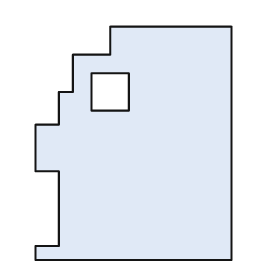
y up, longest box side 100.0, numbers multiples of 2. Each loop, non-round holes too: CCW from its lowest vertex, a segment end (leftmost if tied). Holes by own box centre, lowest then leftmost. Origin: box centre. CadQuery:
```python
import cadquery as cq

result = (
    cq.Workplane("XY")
    .moveTo(-42.0, -50.0)
    .lineTo(42.0, -50.0)
    .lineTo(42.0, 50.0)
    .lineTo(-10.0, 50.0)
    .lineTo(-10.0, 38.0)
    .lineTo(-26.0, 38.0)
    .lineTo(-26.0, 22.0)
    .lineTo(-32.0, 22.0)
    .lineTo(-32.0, 8.0)
    .lineTo(-42.0, 8.0)
    .lineTo(-42.0, -12.0)
    .lineTo(-32.0, -12.0)
    .lineTo(-32.0, -44.0)
    .lineTo(-42.0, -44.0)
    .close()
    .moveTo(-18.0, 14.0)
    .lineTo(-2.0, 14.0)
    .lineTo(-2.0, 30.0)
    .lineTo(-18.0, 30.0)
    .close()
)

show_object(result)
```